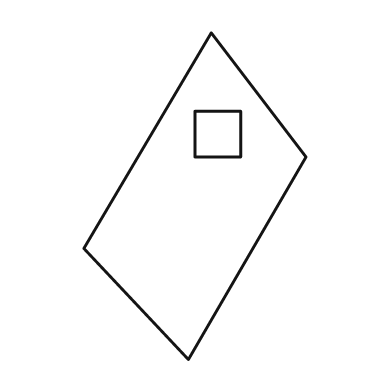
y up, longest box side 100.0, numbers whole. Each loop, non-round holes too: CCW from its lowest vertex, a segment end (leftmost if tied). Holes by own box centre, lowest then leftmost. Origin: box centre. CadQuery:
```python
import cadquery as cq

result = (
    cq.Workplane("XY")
    .moveTo(-2.0, -50.0)
    .lineTo(34.0, 12.0)
    .lineTo(5.0, 50.0)
    .lineTo(-34.0, -16.0)
    .close()
    .moveTo(0.0, 12.0)
    .lineTo(14.0, 12.0)
    .lineTo(14.0, 26.0)
    .lineTo(0.0, 26.0)
    .close()
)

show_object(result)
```